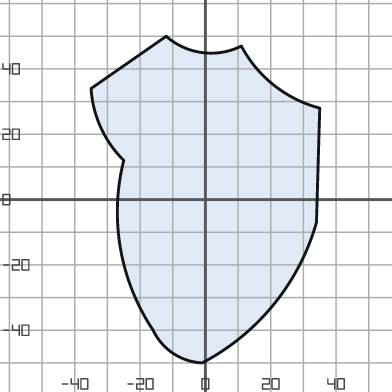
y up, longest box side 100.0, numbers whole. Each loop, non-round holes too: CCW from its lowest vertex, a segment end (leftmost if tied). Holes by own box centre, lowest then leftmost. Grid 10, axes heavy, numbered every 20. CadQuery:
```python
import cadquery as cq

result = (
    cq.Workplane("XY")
    .moveTo(-1.0, -50.0)
    .threePointArc((21.0, -32.0), (34.0, -7.0))
    .lineTo(35.0, 28.0)
    .threePointArc((21.0, 35.0), (11.0, 47.0))
    .threePointArc((-1.0, 45.0), (-12.0, 50.0))
    .lineTo(-35.0, 34.0)
    .threePointArc((-32.0, 22.0), (-25.0, 12.0))
    .threePointArc((-26.0, -15.0), (-16.0, -40.0))
    .threePointArc((-10.0, -47.0), (-1.0, -50.0))
    .close()
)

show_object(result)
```